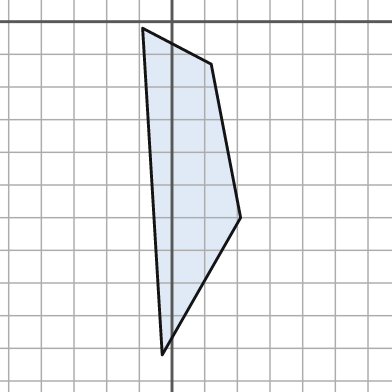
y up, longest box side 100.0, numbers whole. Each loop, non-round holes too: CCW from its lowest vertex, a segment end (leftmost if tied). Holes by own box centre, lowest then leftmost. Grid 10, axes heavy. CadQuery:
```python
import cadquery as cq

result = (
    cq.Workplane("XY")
    .moveTo(-3.0, -102.0)
    .lineTo(21.0, -60.0)
    .lineTo(12.0, -13.0)
    .lineTo(-9.0, -2.0)
    .close()
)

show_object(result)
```